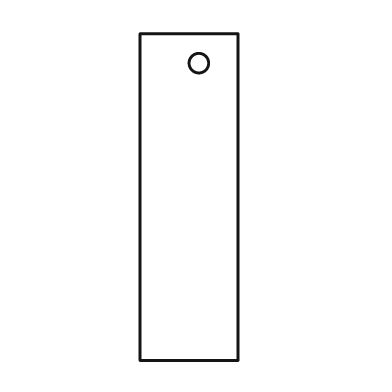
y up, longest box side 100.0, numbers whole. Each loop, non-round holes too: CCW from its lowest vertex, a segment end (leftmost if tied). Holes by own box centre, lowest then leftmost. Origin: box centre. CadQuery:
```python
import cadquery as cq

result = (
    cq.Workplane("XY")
    .moveTo(-15.0, -50.0)
    .lineTo(15.0, -50.0)
    .lineTo(15.0, 50.0)
    .lineTo(-15.0, 50.0)
    .close()
    .moveTo(3.0, 41.0)
    .circle(3.0)
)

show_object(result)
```